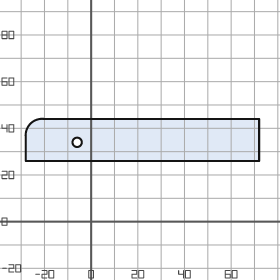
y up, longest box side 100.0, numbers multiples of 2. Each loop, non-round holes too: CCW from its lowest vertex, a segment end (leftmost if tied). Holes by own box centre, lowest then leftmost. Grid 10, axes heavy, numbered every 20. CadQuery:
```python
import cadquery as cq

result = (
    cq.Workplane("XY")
    .moveTo(-28.0, 26.0)
    .lineTo(72.0, 26.0)
    .lineTo(72.0, 44.0)
    .lineTo(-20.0, 44.0)
    .threePointArc((-26.0, 42.0), (-28.0, 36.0))
    .close()
    .moveTo(-6.0, 34.0)
    .circle(2.0)
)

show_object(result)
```